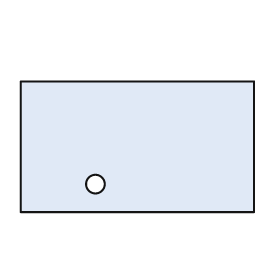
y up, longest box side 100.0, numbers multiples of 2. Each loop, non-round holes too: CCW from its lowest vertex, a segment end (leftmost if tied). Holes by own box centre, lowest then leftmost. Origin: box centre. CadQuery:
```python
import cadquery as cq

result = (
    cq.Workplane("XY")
    .moveTo(-50.0, -28.0)
    .lineTo(50.0, -28.0)
    .lineTo(50.0, 28.0)
    .lineTo(-50.0, 28.0)
    .close()
    .moveTo(-18.0, -16.0)
    .circle(4.0)
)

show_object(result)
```